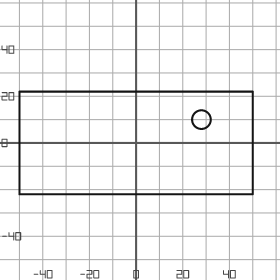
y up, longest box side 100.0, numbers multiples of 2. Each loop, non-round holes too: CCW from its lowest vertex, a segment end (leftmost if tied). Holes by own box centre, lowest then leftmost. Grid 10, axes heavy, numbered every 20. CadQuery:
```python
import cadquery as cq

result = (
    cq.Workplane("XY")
    .moveTo(-50.0, -22.0)
    .lineTo(50.0, -22.0)
    .lineTo(50.0, 22.0)
    .lineTo(-50.0, 22.0)
    .close()
    .moveTo(28.0, 10.0)
    .circle(4.0)
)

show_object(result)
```